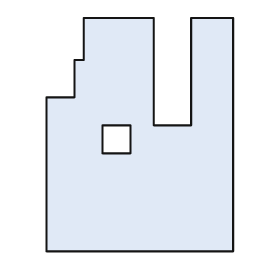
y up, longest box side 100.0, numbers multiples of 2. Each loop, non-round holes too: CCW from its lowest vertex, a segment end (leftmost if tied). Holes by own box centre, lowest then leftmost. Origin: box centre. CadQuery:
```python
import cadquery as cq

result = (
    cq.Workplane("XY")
    .moveTo(-40.0, -50.0)
    .lineTo(40.0, -50.0)
    .lineTo(40.0, 50.0)
    .lineTo(22.0, 50.0)
    .lineTo(22.0, 4.0)
    .lineTo(6.0, 4.0)
    .lineTo(6.0, 50.0)
    .lineTo(-24.0, 50.0)
    .lineTo(-24.0, 32.0)
    .lineTo(-28.0, 32.0)
    .lineTo(-28.0, 16.0)
    .lineTo(-40.0, 16.0)
    .close()
    .moveTo(-16.0, -8.0)
    .lineTo(-4.0, -8.0)
    .lineTo(-4.0, 4.0)
    .lineTo(-16.0, 4.0)
    .close()
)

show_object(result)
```